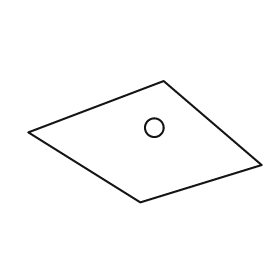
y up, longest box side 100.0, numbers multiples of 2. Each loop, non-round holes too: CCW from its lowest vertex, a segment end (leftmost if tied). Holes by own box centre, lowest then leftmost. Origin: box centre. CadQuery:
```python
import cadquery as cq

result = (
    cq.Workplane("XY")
    .moveTo(-2.0, -26.0)
    .lineTo(50.0, -10.0)
    .lineTo(8.0, 26.0)
    .lineTo(-50.0, 4.0)
    .close()
    .moveTo(4.0, 6.0)
    .circle(4.0)
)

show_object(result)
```